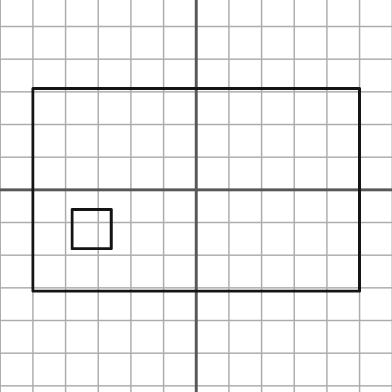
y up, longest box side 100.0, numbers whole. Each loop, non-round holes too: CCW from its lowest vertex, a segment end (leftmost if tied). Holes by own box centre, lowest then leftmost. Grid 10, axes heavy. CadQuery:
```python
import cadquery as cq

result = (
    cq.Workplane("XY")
    .moveTo(-50.0, -31.0)
    .lineTo(50.0, -31.0)
    .lineTo(50.0, 31.0)
    .lineTo(-50.0, 31.0)
    .close()
    .moveTo(-38.0, -18.0)
    .lineTo(-26.0, -18.0)
    .lineTo(-26.0, -6.0)
    .lineTo(-38.0, -6.0)
    .close()
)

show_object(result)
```